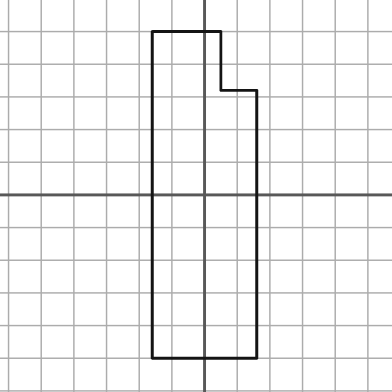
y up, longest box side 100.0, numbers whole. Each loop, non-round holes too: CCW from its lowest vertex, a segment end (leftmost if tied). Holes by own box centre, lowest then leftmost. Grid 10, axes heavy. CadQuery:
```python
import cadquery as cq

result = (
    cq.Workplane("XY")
    .moveTo(-16.0, -50.0)
    .lineTo(16.0, -50.0)
    .lineTo(16.0, 32.0)
    .lineTo(5.0, 32.0)
    .lineTo(5.0, 50.0)
    .lineTo(-16.0, 50.0)
    .close()
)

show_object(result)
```